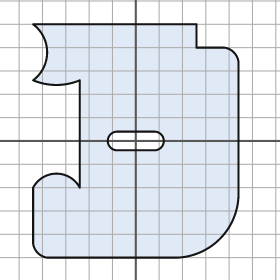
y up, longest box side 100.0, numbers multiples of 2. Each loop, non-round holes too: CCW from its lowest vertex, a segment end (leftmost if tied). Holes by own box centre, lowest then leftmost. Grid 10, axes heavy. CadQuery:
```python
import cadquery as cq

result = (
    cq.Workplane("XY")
    .moveTo(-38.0, -50.0)
    .lineTo(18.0, -50.0)
    .threePointArc((36.0, -42.0), (44.0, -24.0))
    .lineTo(44.0, 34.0)
    .threePointArc((42.0, 38.0), (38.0, 40.0))
    .lineTo(26.0, 40.0)
    .lineTo(26.0, 50.0)
    .lineTo(-44.0, 50.0)
    .threePointArc((-38.0, 38.0), (-44.0, 26.0))
    .threePointArc((-34.0, 24.0), (-24.0, 26.0))
    .lineTo(-24.0, -20.0)
    .threePointArc((-34.0, -14.0), (-44.0, -20.0))
    .lineTo(-44.0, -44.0)
    .threePointArc((-42.0, -48.0), (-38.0, -50.0))
    .close()
    .moveTo(-8.0, -4.0)
    .lineTo(8.0, -4.0)
    .threePointArc((12.0, 0.0), (8.0, 4.0))
    .lineTo(-8.0, 4.0)
    .threePointArc((-12.0, 0.0), (-8.0, -4.0))
    .close()
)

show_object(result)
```